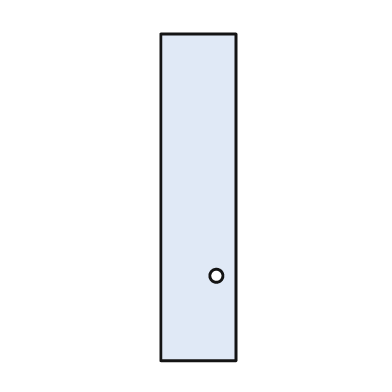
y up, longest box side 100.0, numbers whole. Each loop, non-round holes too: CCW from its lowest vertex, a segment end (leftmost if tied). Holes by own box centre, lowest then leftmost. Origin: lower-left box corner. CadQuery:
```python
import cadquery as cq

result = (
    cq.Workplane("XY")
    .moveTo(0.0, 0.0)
    .lineTo(23.0, 0.0)
    .lineTo(23.0, 100.0)
    .lineTo(0.0, 100.0)
    .close()
    .moveTo(17.0, 26.0)
    .circle(2.0)
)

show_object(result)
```